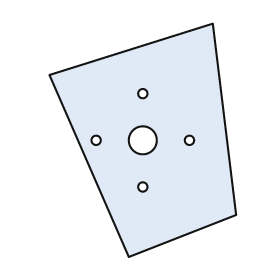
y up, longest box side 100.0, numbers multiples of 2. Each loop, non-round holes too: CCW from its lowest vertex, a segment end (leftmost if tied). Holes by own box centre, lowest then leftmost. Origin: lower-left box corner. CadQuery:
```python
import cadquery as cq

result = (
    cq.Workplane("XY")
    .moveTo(34.0, 0.0)
    .lineTo(80.0, 18.0)
    .lineTo(70.0, 100.0)
    .lineTo(0.0, 78.0)
    .close()
    .moveTo(40.0, 30.0)
    .circle(2.0)
    .moveTo(20.0, 50.0)
    .circle(2.0)
    .moveTo(40.0, 50.0)
    .circle(6.0)
    .moveTo(60.0, 50.0)
    .circle(2.0)
    .moveTo(40.0, 70.0)
    .circle(2.0)
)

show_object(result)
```